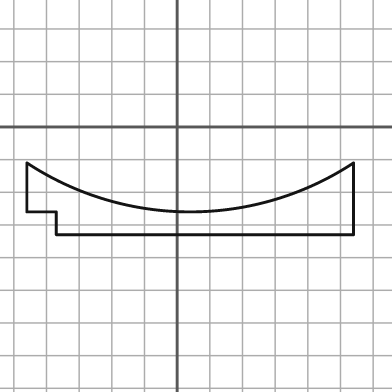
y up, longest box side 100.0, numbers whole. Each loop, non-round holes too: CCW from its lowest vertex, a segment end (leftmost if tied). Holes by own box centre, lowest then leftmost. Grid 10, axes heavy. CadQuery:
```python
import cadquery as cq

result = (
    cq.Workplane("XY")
    .moveTo(-37.0, -33.0)
    .lineTo(54.0, -33.0)
    .lineTo(54.0, -11.0)
    .threePointArc((4.0, -26.0), (-46.0, -11.0))
    .lineTo(-46.0, -26.0)
    .lineTo(-37.0, -26.0)
    .close()
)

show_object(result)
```